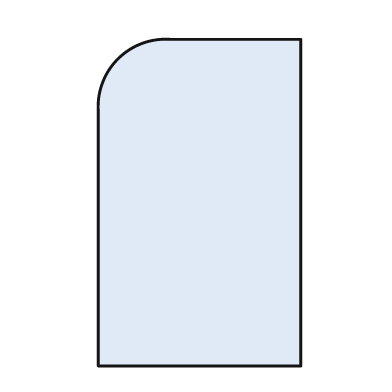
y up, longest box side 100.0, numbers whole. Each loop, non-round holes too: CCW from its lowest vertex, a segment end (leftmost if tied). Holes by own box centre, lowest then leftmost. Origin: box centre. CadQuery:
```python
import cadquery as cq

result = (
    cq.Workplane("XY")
    .moveTo(-31.0, -50.0)
    .lineTo(31.0, -50.0)
    .lineTo(31.0, 50.0)
    .lineTo(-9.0, 50.0)
    .threePointArc((-25.0, 44.0), (-31.0, 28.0))
    .close()
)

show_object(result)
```